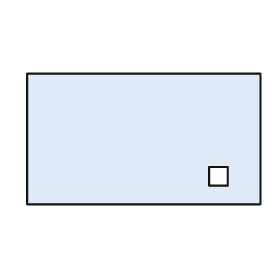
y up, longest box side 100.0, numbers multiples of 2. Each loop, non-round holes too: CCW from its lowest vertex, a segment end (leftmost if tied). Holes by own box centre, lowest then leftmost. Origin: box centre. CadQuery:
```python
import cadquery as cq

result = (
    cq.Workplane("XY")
    .moveTo(-50.0, -28.0)
    .lineTo(50.0, -28.0)
    .lineTo(50.0, 28.0)
    .lineTo(-50.0, 28.0)
    .close()
    .moveTo(28.0, -20.0)
    .lineTo(36.0, -20.0)
    .lineTo(36.0, -12.0)
    .lineTo(28.0, -12.0)
    .close()
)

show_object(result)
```